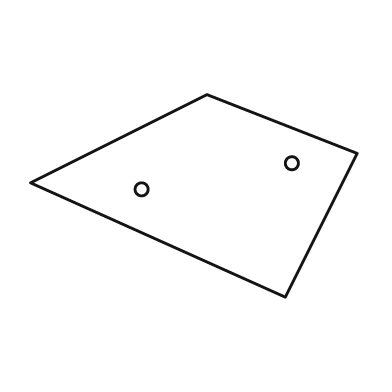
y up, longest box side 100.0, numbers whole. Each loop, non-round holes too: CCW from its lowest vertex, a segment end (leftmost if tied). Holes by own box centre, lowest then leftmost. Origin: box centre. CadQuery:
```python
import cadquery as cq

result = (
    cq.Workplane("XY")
    .moveTo(28.0, -31.0)
    .lineTo(50.0, 13.0)
    .lineTo(4.0, 31.0)
    .lineTo(-50.0, 4.0)
    .close()
    .moveTo(-16.0, 2.0)
    .circle(2.0)
    .moveTo(30.0, 10.0)
    .circle(2.0)
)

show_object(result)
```